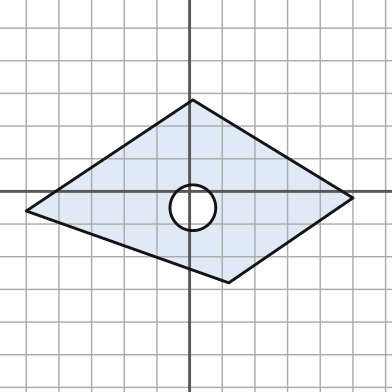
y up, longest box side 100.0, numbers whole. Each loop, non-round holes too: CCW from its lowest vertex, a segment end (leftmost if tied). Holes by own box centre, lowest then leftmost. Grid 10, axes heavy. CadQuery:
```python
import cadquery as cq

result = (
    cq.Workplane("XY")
    .moveTo(12.0, -28.0)
    .lineTo(50.0, -2.0)
    .lineTo(1.0, 28.0)
    .lineTo(-50.0, -6.0)
    .close()
    .moveTo(1.0, -5.0)
    .circle(7.0)
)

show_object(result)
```